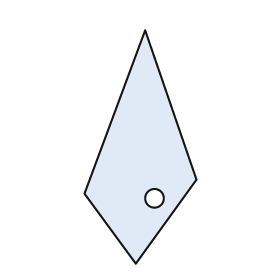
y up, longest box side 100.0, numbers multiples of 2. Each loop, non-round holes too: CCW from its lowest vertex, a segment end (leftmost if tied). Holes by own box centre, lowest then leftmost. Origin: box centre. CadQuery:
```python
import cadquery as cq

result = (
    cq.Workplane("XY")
    .moveTo(-2.0, -50.0)
    .lineTo(24.0, -14.0)
    .lineTo(2.0, 50.0)
    .lineTo(-24.0, -20.0)
    .close()
    .moveTo(6.0, -22.0)
    .circle(4.0)
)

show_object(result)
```